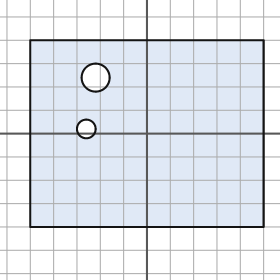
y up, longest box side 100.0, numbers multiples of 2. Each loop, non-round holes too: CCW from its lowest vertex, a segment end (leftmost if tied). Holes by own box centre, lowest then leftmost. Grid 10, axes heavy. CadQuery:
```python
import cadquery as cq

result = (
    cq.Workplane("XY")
    .moveTo(-50.0, -40.0)
    .lineTo(50.0, -40.0)
    .lineTo(50.0, 40.0)
    .lineTo(-50.0, 40.0)
    .close()
    .moveTo(-26.0, 2.0)
    .circle(4.0)
    .moveTo(-22.0, 24.0)
    .circle(6.0)
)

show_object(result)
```